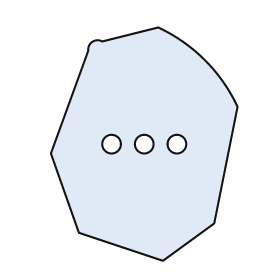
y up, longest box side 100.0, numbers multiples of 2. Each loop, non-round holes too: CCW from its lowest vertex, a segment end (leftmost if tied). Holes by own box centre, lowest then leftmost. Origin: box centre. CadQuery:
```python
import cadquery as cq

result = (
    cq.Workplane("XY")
    .moveTo(8.0, -50.0)
    .lineTo(30.0, -34.0)
    .lineTo(40.0, 16.0)
    .threePointArc((26.0, 36.0), (6.0, 50.0))
    .lineTo(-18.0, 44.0)
    .threePointArc((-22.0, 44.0), (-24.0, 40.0))
    .lineTo(-40.0, -4.0)
    .lineTo(-28.0, -38.0)
    .close()
    .moveTo(-14.0, 0.0)
    .circle(4.0)
    .moveTo(0.0, 0.0)
    .circle(4.0)
    .moveTo(14.0, 0.0)
    .circle(4.0)
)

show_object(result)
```